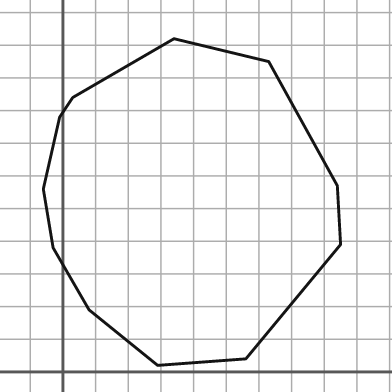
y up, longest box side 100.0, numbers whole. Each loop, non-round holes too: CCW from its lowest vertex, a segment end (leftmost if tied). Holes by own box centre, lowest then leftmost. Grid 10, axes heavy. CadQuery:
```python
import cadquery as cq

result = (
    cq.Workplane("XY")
    .moveTo(29.0, 2.0)
    .lineTo(56.0, 4.0)
    .lineTo(85.0, 39.0)
    .lineTo(84.0, 57.0)
    .lineTo(63.0, 95.0)
    .lineTo(34.0, 102.0)
    .lineTo(3.0, 84.0)
    .lineTo(-1.0, 78.0)
    .lineTo(-6.0, 56.0)
    .lineTo(-3.0, 38.0)
    .lineTo(8.0, 19.0)
    .close()
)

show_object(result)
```